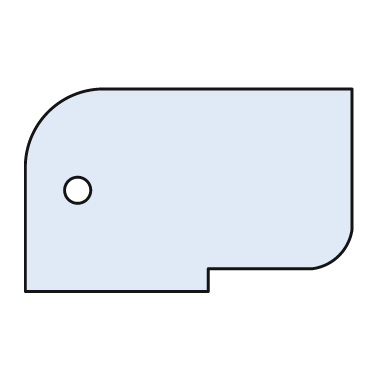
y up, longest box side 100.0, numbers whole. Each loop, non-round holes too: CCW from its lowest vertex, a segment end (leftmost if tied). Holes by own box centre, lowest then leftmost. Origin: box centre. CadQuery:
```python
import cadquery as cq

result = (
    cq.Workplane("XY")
    .moveTo(-50.0, -31.0)
    .lineTo(6.0, -31.0)
    .lineTo(6.0, -24.0)
    .lineTo(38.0, -24.0)
    .threePointArc((46.0, -20.0), (50.0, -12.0))
    .lineTo(50.0, 31.0)
    .lineTo(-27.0, 31.0)
    .threePointArc((-43.0, 24.0), (-50.0, 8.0))
    .close()
    .moveTo(-34.0, 0.0)
    .circle(4.0)
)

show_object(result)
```